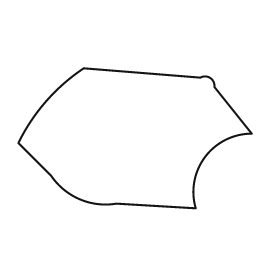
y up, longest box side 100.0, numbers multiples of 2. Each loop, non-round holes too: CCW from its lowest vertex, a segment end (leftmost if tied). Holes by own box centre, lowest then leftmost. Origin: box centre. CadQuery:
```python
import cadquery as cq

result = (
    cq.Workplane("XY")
    .moveTo(26.0, -30.0)
    .threePointArc((30.0, -8.0), (50.0, 2.0))
    .lineTo(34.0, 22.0)
    .threePointArc((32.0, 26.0), (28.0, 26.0))
    .lineTo(-22.0, 30.0)
    .threePointArc((-38.0, 16.0), (-50.0, -2.0))
    .lineTo(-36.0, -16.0)
    .threePointArc((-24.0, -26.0), (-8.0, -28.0))
    .close()
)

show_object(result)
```